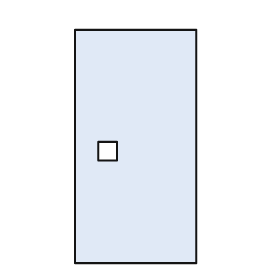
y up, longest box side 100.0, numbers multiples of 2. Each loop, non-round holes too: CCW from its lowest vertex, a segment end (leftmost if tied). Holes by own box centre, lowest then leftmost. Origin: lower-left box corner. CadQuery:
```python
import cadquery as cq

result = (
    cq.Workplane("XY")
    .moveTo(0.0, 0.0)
    .lineTo(52.0, 0.0)
    .lineTo(52.0, 100.0)
    .lineTo(0.0, 100.0)
    .close()
    .moveTo(10.0, 44.0)
    .lineTo(18.0, 44.0)
    .lineTo(18.0, 52.0)
    .lineTo(10.0, 52.0)
    .close()
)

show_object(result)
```